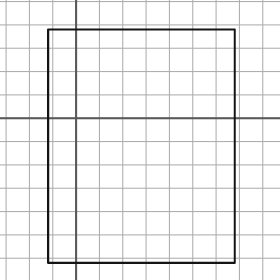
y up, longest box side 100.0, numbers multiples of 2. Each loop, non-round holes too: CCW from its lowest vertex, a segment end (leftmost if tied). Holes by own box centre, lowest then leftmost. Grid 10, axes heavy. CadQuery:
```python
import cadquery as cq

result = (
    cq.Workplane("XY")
    .moveTo(-12.0, -62.0)
    .lineTo(68.0, -62.0)
    .lineTo(68.0, 38.0)
    .lineTo(-12.0, 38.0)
    .close()
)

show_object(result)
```